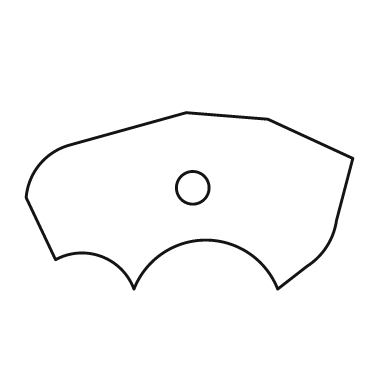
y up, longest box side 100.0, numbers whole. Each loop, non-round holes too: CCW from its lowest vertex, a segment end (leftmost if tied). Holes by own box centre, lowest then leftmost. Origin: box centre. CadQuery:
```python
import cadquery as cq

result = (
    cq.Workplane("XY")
    .moveTo(-17.0, -27.0)
    .threePointArc((5.0, -12.0), (27.0, -27.0))
    .lineTo(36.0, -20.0)
    .threePointArc((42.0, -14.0), (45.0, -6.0))
    .lineTo(50.0, 13.0)
    .lineTo(24.0, 25.0)
    .lineTo(-1.0, 27.0)
    .lineTo(-37.0, 17.0)
    .threePointArc((-46.0, 11.0), (-50.0, 1.0))
    .lineTo(-41.0, -18.0)
    .threePointArc((-27.0, -17.0), (-17.0, -27.0))
    .close()
    .moveTo(1.0, 4.0)
    .circle(5.0)
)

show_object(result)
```